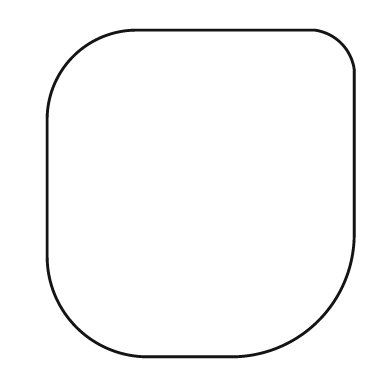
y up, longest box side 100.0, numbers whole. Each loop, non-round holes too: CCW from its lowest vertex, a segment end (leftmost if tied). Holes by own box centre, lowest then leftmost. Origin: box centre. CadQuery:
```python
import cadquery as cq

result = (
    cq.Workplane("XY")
    .moveTo(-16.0, -50.0)
    .lineTo(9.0, -50.0)
    .threePointArc((36.0, -39.0), (47.0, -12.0))
    .lineTo(47.0, 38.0)
    .threePointArc((43.0, 46.0), (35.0, 50.0))
    .lineTo(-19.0, 50.0)
    .threePointArc((-39.0, 42.0), (-47.0, 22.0))
    .lineTo(-47.0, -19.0)
    .threePointArc((-38.0, -41.0), (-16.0, -50.0))
    .close()
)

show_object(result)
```